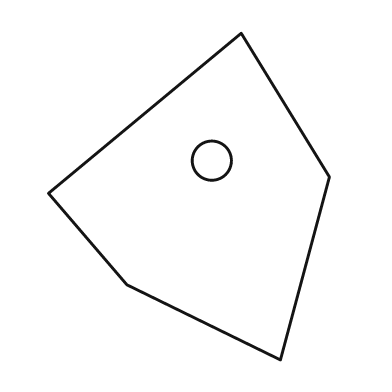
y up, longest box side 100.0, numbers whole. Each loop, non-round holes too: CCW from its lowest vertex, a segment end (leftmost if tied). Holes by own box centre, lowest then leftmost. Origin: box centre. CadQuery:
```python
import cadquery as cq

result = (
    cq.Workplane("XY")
    .moveTo(28.0, -50.0)
    .lineTo(43.0, 6.0)
    .lineTo(16.0, 50.0)
    .lineTo(-43.0, 1.0)
    .lineTo(-19.0, -27.0)
    .close()
    .moveTo(7.0, 11.0)
    .circle(6.0)
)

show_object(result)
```